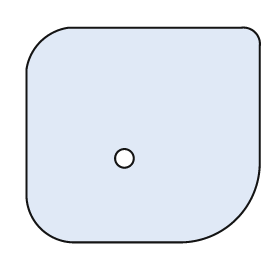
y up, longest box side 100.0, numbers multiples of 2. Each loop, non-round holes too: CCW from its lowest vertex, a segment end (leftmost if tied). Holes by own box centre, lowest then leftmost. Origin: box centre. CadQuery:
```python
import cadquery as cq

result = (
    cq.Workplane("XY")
    .moveTo(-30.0, -46.0)
    .lineTo(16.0, -46.0)
    .threePointArc((40.0, -36.0), (50.0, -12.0))
    .lineTo(50.0, 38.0)
    .threePointArc((48.0, 44.0), (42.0, 46.0))
    .lineTo(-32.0, 46.0)
    .threePointArc((-44.0, 40.0), (-50.0, 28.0))
    .lineTo(-50.0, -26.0)
    .threePointArc((-44.0, -40.0), (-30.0, -46.0))
    .close()
    .moveTo(-8.0, -10.0)
    .circle(4.0)
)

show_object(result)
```